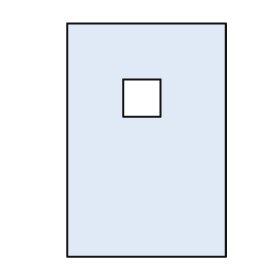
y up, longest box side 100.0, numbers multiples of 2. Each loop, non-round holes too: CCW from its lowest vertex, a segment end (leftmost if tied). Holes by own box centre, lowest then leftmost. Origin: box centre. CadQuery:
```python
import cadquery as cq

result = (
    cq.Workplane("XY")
    .moveTo(-34.0, -50.0)
    .lineTo(34.0, -50.0)
    .lineTo(34.0, 50.0)
    .lineTo(-34.0, 50.0)
    .close()
    .moveTo(-10.0, 10.0)
    .lineTo(6.0, 10.0)
    .lineTo(6.0, 26.0)
    .lineTo(-10.0, 26.0)
    .close()
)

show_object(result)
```